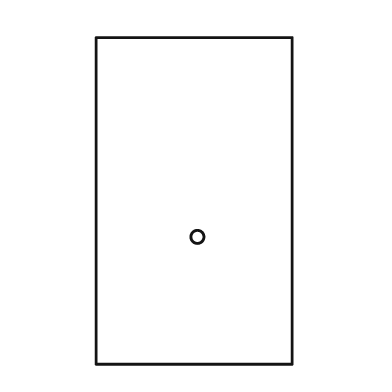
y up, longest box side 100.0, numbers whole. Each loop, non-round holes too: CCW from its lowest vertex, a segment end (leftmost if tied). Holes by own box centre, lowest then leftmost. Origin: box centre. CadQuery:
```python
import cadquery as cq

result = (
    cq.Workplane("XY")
    .moveTo(-30.0, -50.0)
    .lineTo(30.0, -50.0)
    .lineTo(30.0, 50.0)
    .lineTo(-30.0, 50.0)
    .close()
    .moveTo(1.0, -11.0)
    .circle(2.0)
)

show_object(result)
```